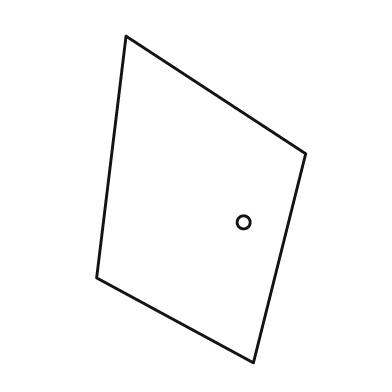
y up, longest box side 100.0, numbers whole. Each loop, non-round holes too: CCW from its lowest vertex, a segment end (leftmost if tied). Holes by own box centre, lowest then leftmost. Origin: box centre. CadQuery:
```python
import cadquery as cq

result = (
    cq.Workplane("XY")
    .moveTo(16.0, -50.0)
    .lineTo(32.0, 14.0)
    .lineTo(-23.0, 50.0)
    .lineTo(-32.0, -24.0)
    .close()
    .moveTo(13.0, -7.0)
    .circle(2.0)
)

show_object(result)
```